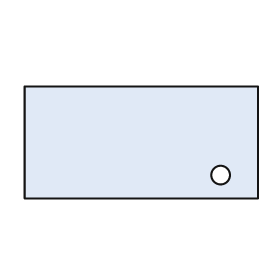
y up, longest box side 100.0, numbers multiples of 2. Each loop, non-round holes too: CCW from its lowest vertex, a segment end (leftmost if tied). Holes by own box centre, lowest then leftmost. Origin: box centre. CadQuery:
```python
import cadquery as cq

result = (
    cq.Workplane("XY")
    .moveTo(-50.0, -24.0)
    .lineTo(50.0, -24.0)
    .lineTo(50.0, 24.0)
    .lineTo(-50.0, 24.0)
    .close()
    .moveTo(34.0, -14.0)
    .circle(4.0)
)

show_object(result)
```